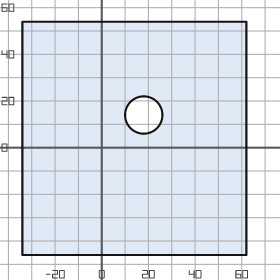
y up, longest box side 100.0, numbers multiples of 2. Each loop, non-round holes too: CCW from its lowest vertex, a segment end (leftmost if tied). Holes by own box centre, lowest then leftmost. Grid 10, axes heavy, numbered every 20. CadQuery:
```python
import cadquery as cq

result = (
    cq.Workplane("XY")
    .moveTo(-34.0, -46.0)
    .lineTo(62.0, -46.0)
    .lineTo(62.0, 54.0)
    .lineTo(-34.0, 54.0)
    .close()
    .moveTo(18.0, 14.0)
    .circle(8.0)
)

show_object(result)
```